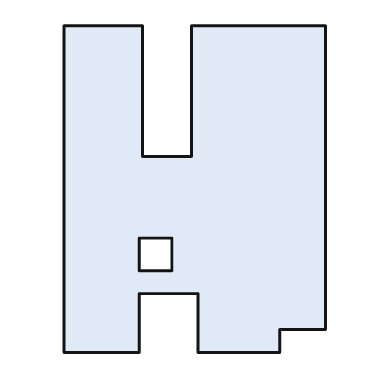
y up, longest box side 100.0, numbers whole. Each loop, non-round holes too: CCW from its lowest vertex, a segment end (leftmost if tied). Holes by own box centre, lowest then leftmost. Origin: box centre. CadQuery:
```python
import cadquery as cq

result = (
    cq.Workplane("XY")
    .moveTo(-40.0, -50.0)
    .lineTo(-17.0, -50.0)
    .lineTo(-17.0, -32.0)
    .lineTo(1.0, -32.0)
    .lineTo(1.0, -50.0)
    .lineTo(26.0, -50.0)
    .lineTo(26.0, -43.0)
    .lineTo(40.0, -43.0)
    .lineTo(40.0, 50.0)
    .lineTo(-1.0, 50.0)
    .lineTo(-1.0, 10.0)
    .lineTo(-16.0, 10.0)
    .lineTo(-16.0, 50.0)
    .lineTo(-40.0, 50.0)
    .close()
    .moveTo(-17.0, -25.0)
    .lineTo(-7.0, -25.0)
    .lineTo(-7.0, -15.0)
    .lineTo(-17.0, -15.0)
    .close()
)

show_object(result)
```